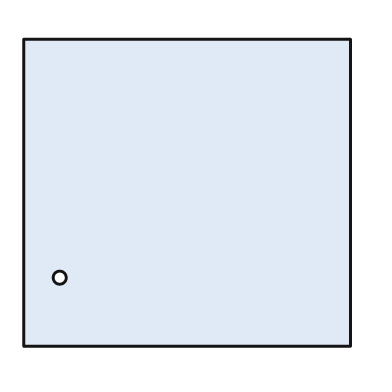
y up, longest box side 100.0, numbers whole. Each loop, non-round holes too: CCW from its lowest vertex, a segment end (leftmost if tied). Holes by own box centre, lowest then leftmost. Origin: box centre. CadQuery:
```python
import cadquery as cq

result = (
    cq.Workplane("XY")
    .moveTo(-50.0, -47.0)
    .lineTo(50.0, -47.0)
    .lineTo(50.0, 47.0)
    .lineTo(-50.0, 47.0)
    .close()
    .moveTo(-39.0, -26.0)
    .circle(2.0)
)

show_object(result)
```